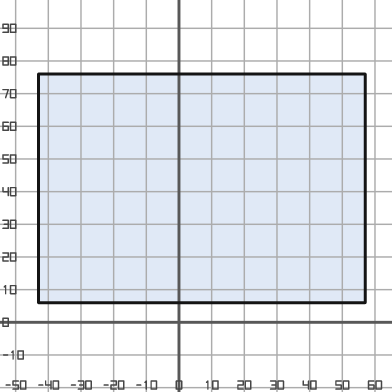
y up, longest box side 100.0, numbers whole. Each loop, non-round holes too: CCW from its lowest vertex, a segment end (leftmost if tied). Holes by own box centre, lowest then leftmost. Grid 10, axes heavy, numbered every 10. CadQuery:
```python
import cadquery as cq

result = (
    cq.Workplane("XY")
    .moveTo(-43.0, 6.0)
    .lineTo(57.0, 6.0)
    .lineTo(57.0, 76.0)
    .lineTo(-43.0, 76.0)
    .close()
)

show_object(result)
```